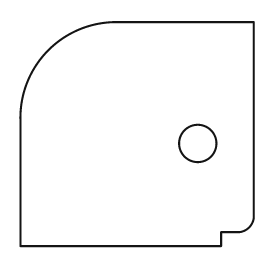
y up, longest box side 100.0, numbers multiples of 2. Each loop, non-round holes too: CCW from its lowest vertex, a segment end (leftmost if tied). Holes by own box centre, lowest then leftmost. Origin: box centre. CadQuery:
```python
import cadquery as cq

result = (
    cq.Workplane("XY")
    .moveTo(-50.0, -48.0)
    .lineTo(36.0, -48.0)
    .lineTo(36.0, -42.0)
    .lineTo(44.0, -42.0)
    .threePointArc((48.0, -40.0), (50.0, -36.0))
    .lineTo(50.0, 48.0)
    .lineTo(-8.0, 48.0)
    .threePointArc((-38.0, 36.0), (-50.0, 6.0))
    .close()
    .moveTo(26.0, -4.0)
    .circle(8.0)
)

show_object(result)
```